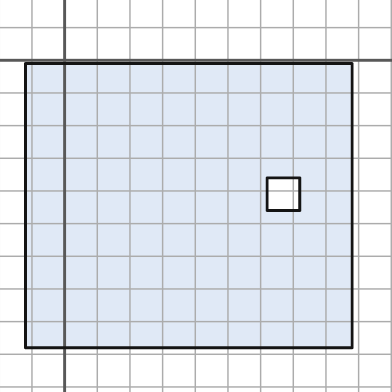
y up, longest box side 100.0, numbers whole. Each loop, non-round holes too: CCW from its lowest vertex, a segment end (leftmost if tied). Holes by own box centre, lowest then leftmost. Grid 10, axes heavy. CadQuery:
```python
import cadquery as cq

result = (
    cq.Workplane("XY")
    .moveTo(-12.0, -88.0)
    .lineTo(88.0, -88.0)
    .lineTo(88.0, -1.0)
    .lineTo(-12.0, -1.0)
    .close()
    .moveTo(62.0, -46.0)
    .lineTo(72.0, -46.0)
    .lineTo(72.0, -36.0)
    .lineTo(62.0, -36.0)
    .close()
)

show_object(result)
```